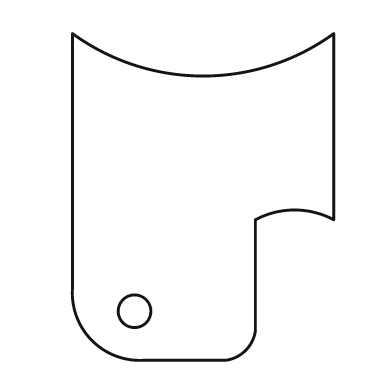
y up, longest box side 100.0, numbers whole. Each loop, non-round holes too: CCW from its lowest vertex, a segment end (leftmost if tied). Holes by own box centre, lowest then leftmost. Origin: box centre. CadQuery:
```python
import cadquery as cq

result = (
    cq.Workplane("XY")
    .moveTo(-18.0, -50.0)
    .lineTo(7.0, -50.0)
    .threePointArc((13.0, -47.0), (16.0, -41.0))
    .lineTo(16.0, -7.0)
    .threePointArc((28.0, -4.0), (40.0, -7.0))
    .lineTo(40.0, 50.0)
    .threePointArc((0.0, 37.0), (-40.0, 50.0))
    .lineTo(-40.0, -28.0)
    .threePointArc((-34.0, -44.0), (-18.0, -50.0))
    .close()
    .moveTo(-21.0, -35.0)
    .circle(5.0)
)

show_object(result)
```